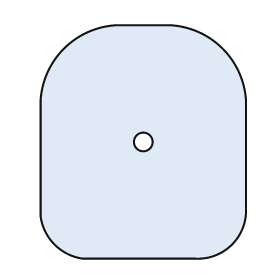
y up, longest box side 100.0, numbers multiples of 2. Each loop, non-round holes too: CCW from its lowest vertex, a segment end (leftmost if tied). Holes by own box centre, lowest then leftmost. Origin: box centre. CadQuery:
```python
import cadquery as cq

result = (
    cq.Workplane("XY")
    .moveTo(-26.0, -50.0)
    .lineTo(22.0, -50.0)
    .threePointArc((38.0, -44.0), (44.0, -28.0))
    .lineTo(44.0, 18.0)
    .threePointArc((34.0, 40.0), (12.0, 50.0))
    .lineTo(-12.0, 50.0)
    .threePointArc((-34.0, 40.0), (-44.0, 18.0))
    .lineTo(-44.0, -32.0)
    .threePointArc((-38.0, -44.0), (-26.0, -50.0))
    .close()
    .moveTo(0.0, 0.0)
    .circle(4.0)
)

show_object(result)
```